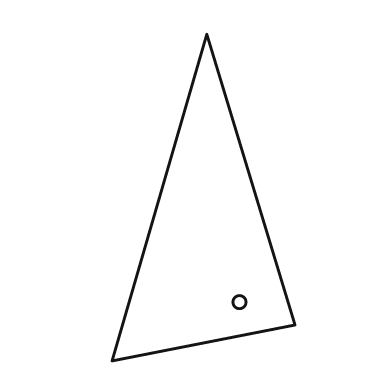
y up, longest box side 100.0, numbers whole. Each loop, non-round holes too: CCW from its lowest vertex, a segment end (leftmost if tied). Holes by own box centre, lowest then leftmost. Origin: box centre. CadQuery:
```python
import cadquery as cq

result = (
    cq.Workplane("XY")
    .moveTo(-28.0, -50.0)
    .lineTo(28.0, -39.0)
    .lineTo(1.0, 50.0)
    .close()
    .moveTo(11.0, -32.0)
    .circle(2.0)
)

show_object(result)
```